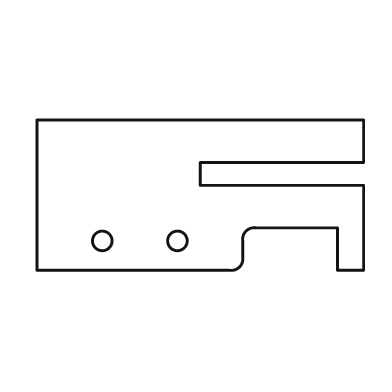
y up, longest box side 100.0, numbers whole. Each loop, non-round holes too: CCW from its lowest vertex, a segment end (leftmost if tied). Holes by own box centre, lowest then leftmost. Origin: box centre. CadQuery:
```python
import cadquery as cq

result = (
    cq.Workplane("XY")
    .moveTo(-50.0, -23.0)
    .lineTo(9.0, -23.0)
    .threePointArc((12.0, -22.0), (13.0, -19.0))
    .lineTo(13.0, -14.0)
    .threePointArc((14.0, -11.0), (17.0, -10.0))
    .lineTo(42.0, -10.0)
    .lineTo(42.0, -23.0)
    .lineTo(50.0, -23.0)
    .lineTo(50.0, 3.0)
    .lineTo(0.0, 3.0)
    .lineTo(0.0, 10.0)
    .lineTo(50.0, 10.0)
    .lineTo(50.0, 23.0)
    .lineTo(-50.0, 23.0)
    .close()
    .moveTo(-30.0, -14.0)
    .circle(3.0)
    .moveTo(-7.0, -14.0)
    .circle(3.0)
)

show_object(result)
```